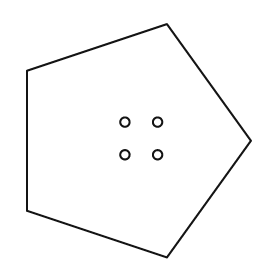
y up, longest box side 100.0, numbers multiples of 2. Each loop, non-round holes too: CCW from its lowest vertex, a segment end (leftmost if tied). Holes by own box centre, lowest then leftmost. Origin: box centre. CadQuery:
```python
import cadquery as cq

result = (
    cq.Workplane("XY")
    .moveTo(12.0, -50.0)
    .lineTo(48.0, 0.0)
    .lineTo(12.0, 50.0)
    .lineTo(-48.0, 30.0)
    .lineTo(-48.0, -30.0)
    .close()
    .moveTo(-6.0, -6.0)
    .circle(2.0)
    .moveTo(8.0, -6.0)
    .circle(2.0)
    .moveTo(-6.0, 8.0)
    .circle(2.0)
    .moveTo(8.0, 8.0)
    .circle(2.0)
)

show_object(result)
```